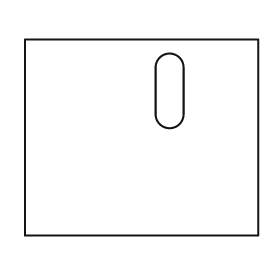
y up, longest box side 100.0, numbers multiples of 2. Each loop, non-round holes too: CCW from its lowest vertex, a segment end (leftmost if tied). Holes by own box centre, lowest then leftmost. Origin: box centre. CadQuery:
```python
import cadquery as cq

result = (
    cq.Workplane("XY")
    .moveTo(-50.0, -42.0)
    .lineTo(50.0, -42.0)
    .lineTo(50.0, 42.0)
    .lineTo(-50.0, 42.0)
    .close()
    .moveTo(6.0, 10.0)
    .threePointArc((12.0, 4.0), (18.0, 10.0))
    .lineTo(18.0, 30.0)
    .threePointArc((12.0, 36.0), (6.0, 30.0))
    .close()
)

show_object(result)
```